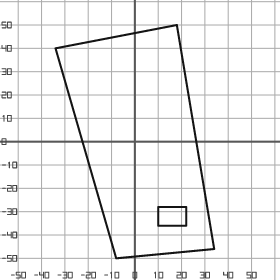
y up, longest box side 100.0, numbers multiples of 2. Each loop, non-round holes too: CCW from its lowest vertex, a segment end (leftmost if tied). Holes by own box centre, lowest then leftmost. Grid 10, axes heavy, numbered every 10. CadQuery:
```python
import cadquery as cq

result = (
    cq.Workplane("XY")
    .moveTo(-8.0, -50.0)
    .lineTo(34.0, -46.0)
    .lineTo(18.0, 50.0)
    .lineTo(-34.0, 40.0)
    .close()
    .moveTo(10.0, -36.0)
    .lineTo(22.0, -36.0)
    .lineTo(22.0, -28.0)
    .lineTo(10.0, -28.0)
    .close()
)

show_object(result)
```